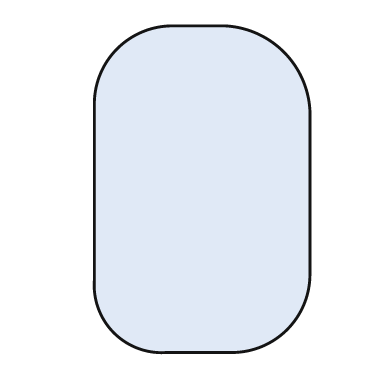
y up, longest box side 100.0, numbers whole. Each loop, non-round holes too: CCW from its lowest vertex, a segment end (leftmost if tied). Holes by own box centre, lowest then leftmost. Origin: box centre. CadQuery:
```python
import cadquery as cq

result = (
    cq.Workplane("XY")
    .moveTo(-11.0, -50.0)
    .lineTo(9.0, -50.0)
    .threePointArc((26.0, -43.0), (33.0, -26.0))
    .lineTo(33.0, 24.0)
    .threePointArc((25.0, 42.0), (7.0, 50.0))
    .lineTo(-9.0, 50.0)
    .threePointArc((-26.0, 43.0), (-33.0, 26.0))
    .lineTo(-33.0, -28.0)
    .threePointArc((-27.0, -44.0), (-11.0, -50.0))
    .close()
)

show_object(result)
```